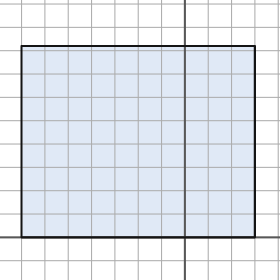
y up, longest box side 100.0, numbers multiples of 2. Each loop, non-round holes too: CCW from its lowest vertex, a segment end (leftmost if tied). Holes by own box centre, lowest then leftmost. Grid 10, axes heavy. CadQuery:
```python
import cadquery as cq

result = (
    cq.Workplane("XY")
    .moveTo(-70.0, 0.0)
    .lineTo(30.0, 0.0)
    .lineTo(30.0, 82.0)
    .lineTo(-70.0, 82.0)
    .close()
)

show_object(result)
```